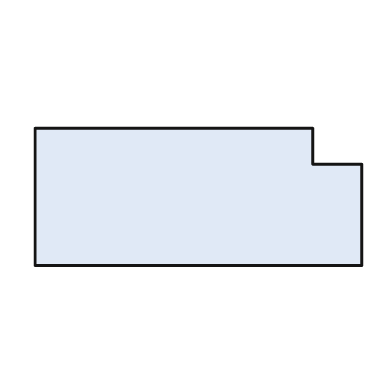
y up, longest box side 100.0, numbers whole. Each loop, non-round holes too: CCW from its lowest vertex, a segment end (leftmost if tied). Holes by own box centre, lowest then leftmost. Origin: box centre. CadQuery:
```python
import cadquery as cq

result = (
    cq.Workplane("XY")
    .moveTo(-50.0, -21.0)
    .lineTo(50.0, -21.0)
    .lineTo(50.0, 10.0)
    .lineTo(35.0, 10.0)
    .lineTo(35.0, 21.0)
    .lineTo(-50.0, 21.0)
    .close()
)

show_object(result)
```